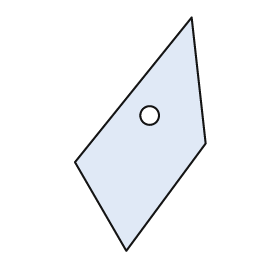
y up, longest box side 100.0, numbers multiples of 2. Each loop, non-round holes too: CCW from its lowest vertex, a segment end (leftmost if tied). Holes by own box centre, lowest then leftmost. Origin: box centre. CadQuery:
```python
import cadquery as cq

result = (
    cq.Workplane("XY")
    .moveTo(-6.0, -50.0)
    .lineTo(28.0, -4.0)
    .lineTo(22.0, 50.0)
    .lineTo(-28.0, -12.0)
    .close()
    .moveTo(4.0, 8.0)
    .circle(4.0)
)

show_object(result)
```